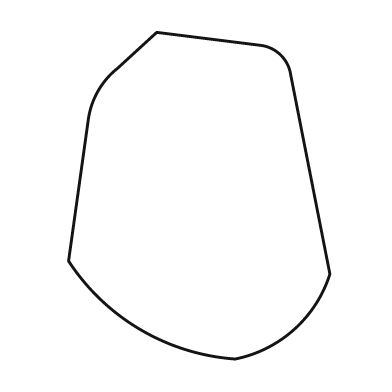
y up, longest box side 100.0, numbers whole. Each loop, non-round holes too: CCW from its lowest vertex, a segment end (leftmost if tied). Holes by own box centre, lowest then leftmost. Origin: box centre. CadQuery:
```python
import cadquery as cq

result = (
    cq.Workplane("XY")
    .moveTo(11.0, -50.0)
    .threePointArc((29.0, -41.0), (40.0, -24.0))
    .lineTo(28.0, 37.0)
    .threePointArc((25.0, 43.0), (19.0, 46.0))
    .lineTo(-13.0, 50.0)
    .lineTo(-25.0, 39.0)
    .threePointArc((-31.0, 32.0), (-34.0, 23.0))
    .lineTo(-40.0, -20.0)
    .threePointArc((-18.0, -41.0), (11.0, -50.0))
    .close()
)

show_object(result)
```